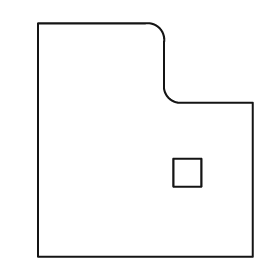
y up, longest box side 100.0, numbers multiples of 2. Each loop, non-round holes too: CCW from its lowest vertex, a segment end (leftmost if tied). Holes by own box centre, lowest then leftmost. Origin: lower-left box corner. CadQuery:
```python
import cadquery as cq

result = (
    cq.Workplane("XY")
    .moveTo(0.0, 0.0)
    .lineTo(92.0, 0.0)
    .lineTo(92.0, 66.0)
    .lineTo(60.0, 66.0)
    .threePointArc((56.0, 68.0), (54.0, 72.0))
    .lineTo(54.0, 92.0)
    .threePointArc((52.0, 98.0), (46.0, 100.0))
    .lineTo(0.0, 100.0)
    .close()
    .moveTo(58.0, 30.0)
    .lineTo(70.0, 30.0)
    .lineTo(70.0, 42.0)
    .lineTo(58.0, 42.0)
    .close()
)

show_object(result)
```